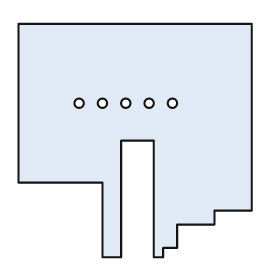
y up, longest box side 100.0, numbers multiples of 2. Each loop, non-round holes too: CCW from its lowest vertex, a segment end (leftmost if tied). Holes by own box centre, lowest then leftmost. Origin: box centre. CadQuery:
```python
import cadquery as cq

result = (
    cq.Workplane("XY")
    .moveTo(-14.0, -50.0)
    .lineTo(-6.0, -50.0)
    .lineTo(-6.0, 0.0)
    .lineTo(8.0, 0.0)
    .lineTo(8.0, -50.0)
    .lineTo(12.0, -50.0)
    .lineTo(12.0, -46.0)
    .lineTo(18.0, -46.0)
    .lineTo(18.0, -36.0)
    .lineTo(34.0, -36.0)
    .lineTo(34.0, -30.0)
    .lineTo(50.0, -30.0)
    .lineTo(50.0, 50.0)
    .lineTo(-50.0, 50.0)
    .lineTo(-50.0, -18.0)
    .lineTo(-14.0, -18.0)
    .close()
    .moveTo(-24.0, 16.0)
    .circle(2.0)
    .moveTo(-14.0, 16.0)
    .circle(2.0)
    .moveTo(-4.0, 16.0)
    .circle(2.0)
    .moveTo(6.0, 16.0)
    .circle(2.0)
    .moveTo(16.0, 16.0)
    .circle(2.0)
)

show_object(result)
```